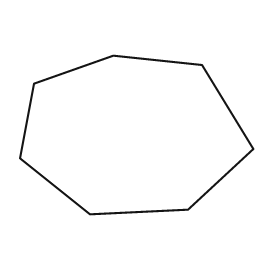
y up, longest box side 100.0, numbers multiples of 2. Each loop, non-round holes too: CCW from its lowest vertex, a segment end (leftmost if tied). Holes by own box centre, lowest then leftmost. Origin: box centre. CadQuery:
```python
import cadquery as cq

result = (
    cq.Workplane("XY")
    .moveTo(-20.0, -34.0)
    .lineTo(22.0, -32.0)
    .lineTo(50.0, -6.0)
    .lineTo(28.0, 30.0)
    .lineTo(-10.0, 34.0)
    .lineTo(-44.0, 22.0)
    .lineTo(-50.0, -10.0)
    .close()
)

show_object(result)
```